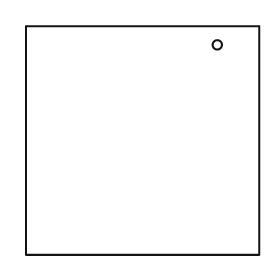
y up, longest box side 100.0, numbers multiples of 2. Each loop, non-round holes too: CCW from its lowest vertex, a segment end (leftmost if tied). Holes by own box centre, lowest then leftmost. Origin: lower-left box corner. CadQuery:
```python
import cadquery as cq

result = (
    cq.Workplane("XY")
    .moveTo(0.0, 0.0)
    .lineTo(100.0, 0.0)
    .lineTo(100.0, 98.0)
    .lineTo(0.0, 98.0)
    .close()
    .moveTo(82.0, 90.0)
    .circle(2.0)
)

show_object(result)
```